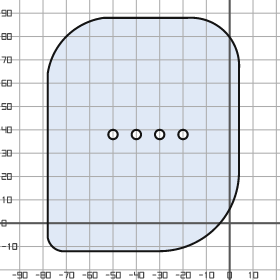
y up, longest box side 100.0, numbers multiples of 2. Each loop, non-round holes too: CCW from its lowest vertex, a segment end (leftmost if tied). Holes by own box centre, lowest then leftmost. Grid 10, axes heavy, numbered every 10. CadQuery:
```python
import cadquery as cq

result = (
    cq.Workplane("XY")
    .moveTo(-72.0, -12.0)
    .lineTo(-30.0, -12.0)
    .threePointArc((-6.0, -2.0), (4.0, 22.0))
    .lineTo(4.0, 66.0)
    .threePointArc((-2.0, 82.0), (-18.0, 88.0))
    .lineTo(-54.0, 88.0)
    .threePointArc((-70.0, 80.0), (-78.0, 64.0))
    .lineTo(-78.0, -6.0)
    .threePointArc((-76.0, -10.0), (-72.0, -12.0))
    .close()
    .moveTo(-50.0, 38.0)
    .circle(2.0)
    .moveTo(-40.0, 38.0)
    .circle(2.0)
    .moveTo(-30.0, 38.0)
    .circle(2.0)
    .moveTo(-20.0, 38.0)
    .circle(2.0)
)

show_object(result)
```